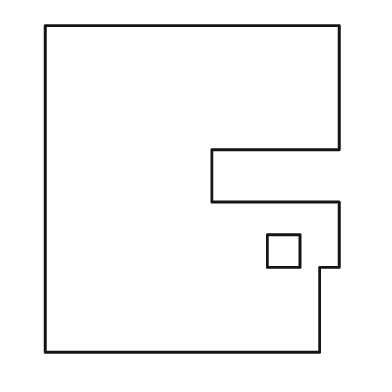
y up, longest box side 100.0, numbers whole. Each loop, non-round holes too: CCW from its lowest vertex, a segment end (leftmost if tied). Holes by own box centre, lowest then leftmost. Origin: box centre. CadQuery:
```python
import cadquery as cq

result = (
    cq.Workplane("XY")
    .moveTo(-45.0, -50.0)
    .lineTo(39.0, -50.0)
    .lineTo(39.0, -24.0)
    .lineTo(45.0, -24.0)
    .lineTo(45.0, -4.0)
    .lineTo(6.0, -4.0)
    .lineTo(6.0, 12.0)
    .lineTo(45.0, 12.0)
    .lineTo(45.0, 50.0)
    .lineTo(-45.0, 50.0)
    .close()
    .moveTo(23.0, -24.0)
    .lineTo(33.0, -24.0)
    .lineTo(33.0, -14.0)
    .lineTo(23.0, -14.0)
    .close()
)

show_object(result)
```